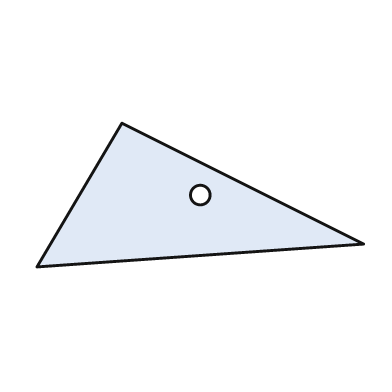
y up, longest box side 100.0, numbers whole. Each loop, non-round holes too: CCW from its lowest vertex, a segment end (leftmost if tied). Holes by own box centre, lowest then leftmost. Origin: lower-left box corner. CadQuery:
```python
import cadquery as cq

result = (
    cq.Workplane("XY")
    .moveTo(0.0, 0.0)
    .lineTo(100.0, 7.0)
    .lineTo(26.0, 44.0)
    .close()
    .moveTo(50.0, 22.0)
    .circle(3.0)
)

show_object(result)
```